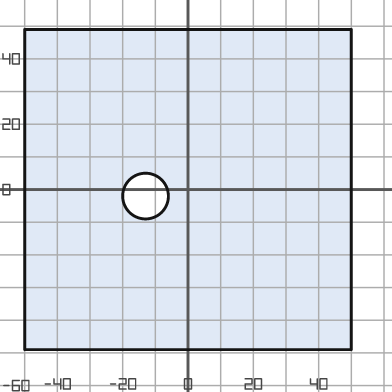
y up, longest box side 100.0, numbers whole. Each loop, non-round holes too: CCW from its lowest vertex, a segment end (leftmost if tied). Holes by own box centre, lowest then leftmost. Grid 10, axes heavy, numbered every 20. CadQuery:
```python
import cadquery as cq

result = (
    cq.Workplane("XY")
    .moveTo(-50.0, -49.0)
    .lineTo(50.0, -49.0)
    .lineTo(50.0, 49.0)
    .lineTo(-50.0, 49.0)
    .close()
    .moveTo(-13.0, -2.0)
    .circle(7.0)
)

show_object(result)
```